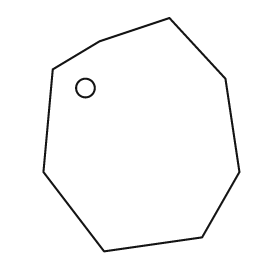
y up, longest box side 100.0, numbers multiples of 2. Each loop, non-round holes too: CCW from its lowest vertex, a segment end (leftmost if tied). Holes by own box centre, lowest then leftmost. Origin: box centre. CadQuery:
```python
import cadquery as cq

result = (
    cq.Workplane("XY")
    .moveTo(-16.0, -50.0)
    .lineTo(26.0, -44.0)
    .lineTo(42.0, -16.0)
    .lineTo(36.0, 24.0)
    .lineTo(12.0, 50.0)
    .lineTo(-18.0, 40.0)
    .lineTo(-38.0, 28.0)
    .lineTo(-42.0, -16.0)
    .close()
    .moveTo(-24.0, 20.0)
    .circle(4.0)
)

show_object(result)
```